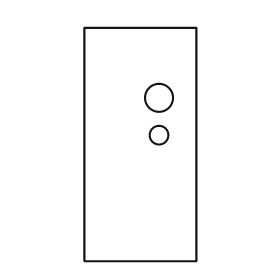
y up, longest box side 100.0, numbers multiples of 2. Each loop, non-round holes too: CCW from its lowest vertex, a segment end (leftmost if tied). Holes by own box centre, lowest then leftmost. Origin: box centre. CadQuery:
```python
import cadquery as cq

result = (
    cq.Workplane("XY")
    .moveTo(-24.0, -50.0)
    .lineTo(24.0, -50.0)
    .lineTo(24.0, 50.0)
    .lineTo(-24.0, 50.0)
    .close()
    .moveTo(8.0, 4.0)
    .circle(4.0)
    .moveTo(8.0, 20.0)
    .circle(6.0)
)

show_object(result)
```